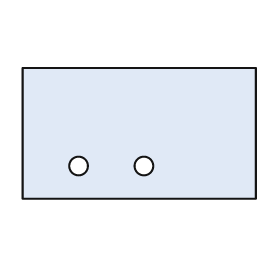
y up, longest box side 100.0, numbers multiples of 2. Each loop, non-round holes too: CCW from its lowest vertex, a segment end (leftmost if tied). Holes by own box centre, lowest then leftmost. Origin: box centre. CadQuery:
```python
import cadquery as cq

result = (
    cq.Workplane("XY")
    .moveTo(-50.0, -28.0)
    .lineTo(50.0, -28.0)
    .lineTo(50.0, 28.0)
    .lineTo(-50.0, 28.0)
    .close()
    .moveTo(-26.0, -14.0)
    .circle(4.0)
    .moveTo(2.0, -14.0)
    .circle(4.0)
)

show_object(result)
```